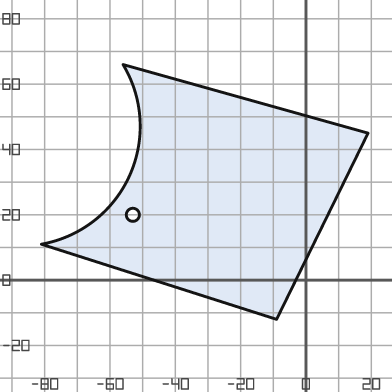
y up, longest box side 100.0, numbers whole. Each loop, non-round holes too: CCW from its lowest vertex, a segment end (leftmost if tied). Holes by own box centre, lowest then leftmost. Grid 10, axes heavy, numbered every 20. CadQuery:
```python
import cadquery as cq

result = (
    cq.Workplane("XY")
    .moveTo(-9.0, -12.0)
    .lineTo(19.0, 45.0)
    .lineTo(-56.0, 66.0)
    .threePointArc((-54.0, 32.0), (-81.0, 11.0))
    .close()
    .moveTo(-53.0, 20.0)
    .circle(2.0)
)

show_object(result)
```